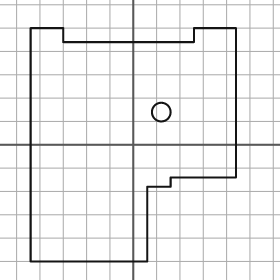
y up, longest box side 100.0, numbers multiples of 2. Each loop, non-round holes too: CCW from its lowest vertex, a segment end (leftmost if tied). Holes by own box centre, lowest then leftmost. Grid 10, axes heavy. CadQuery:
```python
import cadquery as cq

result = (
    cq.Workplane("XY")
    .moveTo(-44.0, -50.0)
    .lineTo(6.0, -50.0)
    .lineTo(6.0, -18.0)
    .lineTo(16.0, -18.0)
    .lineTo(16.0, -14.0)
    .lineTo(44.0, -14.0)
    .lineTo(44.0, 50.0)
    .lineTo(26.0, 50.0)
    .lineTo(26.0, 44.0)
    .lineTo(-30.0, 44.0)
    .lineTo(-30.0, 50.0)
    .lineTo(-44.0, 50.0)
    .close()
    .moveTo(12.0, 14.0)
    .circle(4.0)
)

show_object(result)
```